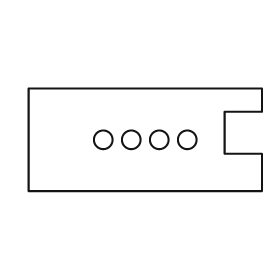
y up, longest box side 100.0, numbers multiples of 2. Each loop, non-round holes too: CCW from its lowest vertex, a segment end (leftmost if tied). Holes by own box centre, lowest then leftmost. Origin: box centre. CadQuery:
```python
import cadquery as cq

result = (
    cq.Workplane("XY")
    .moveTo(-50.0, -22.0)
    .lineTo(50.0, -22.0)
    .lineTo(50.0, -6.0)
    .lineTo(34.0, -6.0)
    .lineTo(34.0, 12.0)
    .lineTo(50.0, 12.0)
    .lineTo(50.0, 22.0)
    .lineTo(-50.0, 22.0)
    .close()
    .moveTo(-18.0, 0.0)
    .circle(4.0)
    .moveTo(-6.0, 0.0)
    .circle(4.0)
    .moveTo(6.0, 0.0)
    .circle(4.0)
    .moveTo(18.0, 0.0)
    .circle(4.0)
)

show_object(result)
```